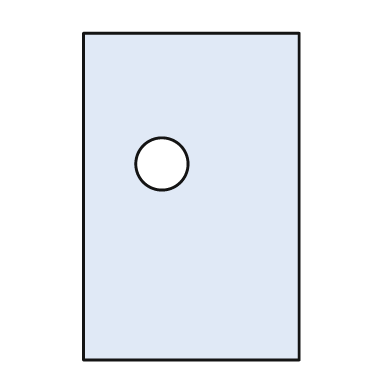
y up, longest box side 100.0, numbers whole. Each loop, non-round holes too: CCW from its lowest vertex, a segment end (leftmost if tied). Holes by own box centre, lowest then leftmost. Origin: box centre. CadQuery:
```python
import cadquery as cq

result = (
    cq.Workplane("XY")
    .moveTo(-33.0, -50.0)
    .lineTo(33.0, -50.0)
    .lineTo(33.0, 50.0)
    .lineTo(-33.0, 50.0)
    .close()
    .moveTo(-9.0, 10.0)
    .circle(8.0)
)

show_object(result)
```